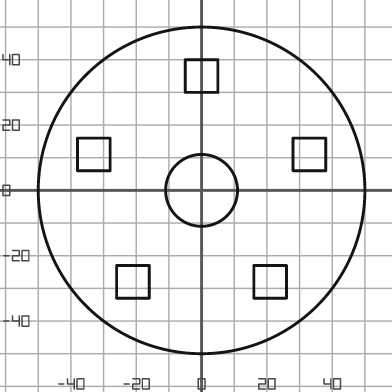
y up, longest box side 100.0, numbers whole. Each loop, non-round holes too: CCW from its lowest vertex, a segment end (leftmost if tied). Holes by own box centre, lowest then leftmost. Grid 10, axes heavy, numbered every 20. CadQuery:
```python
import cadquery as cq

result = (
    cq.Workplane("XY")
    .moveTo(0.0, 0.0)
    .circle(50.0)
    .moveTo(-26.0, -33.0)
    .lineTo(-16.0, -33.0)
    .lineTo(-16.0, -23.0)
    .lineTo(-26.0, -23.0)
    .close()
    .moveTo(16.0, -33.0)
    .lineTo(26.0, -33.0)
    .lineTo(26.0, -23.0)
    .lineTo(16.0, -23.0)
    .close()
    .moveTo(0.0, 0.0)
    .circle(11.0)
    .moveTo(-38.0, 6.0)
    .lineTo(-28.0, 6.0)
    .lineTo(-28.0, 16.0)
    .lineTo(-38.0, 16.0)
    .close()
    .moveTo(28.0, 6.0)
    .lineTo(38.0, 6.0)
    .lineTo(38.0, 16.0)
    .lineTo(28.0, 16.0)
    .close()
    .moveTo(-5.0, 30.0)
    .lineTo(5.0, 30.0)
    .lineTo(5.0, 40.0)
    .lineTo(-5.0, 40.0)
    .close()
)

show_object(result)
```